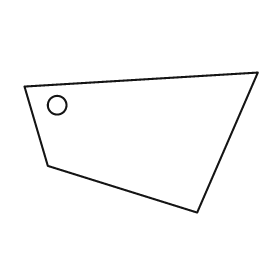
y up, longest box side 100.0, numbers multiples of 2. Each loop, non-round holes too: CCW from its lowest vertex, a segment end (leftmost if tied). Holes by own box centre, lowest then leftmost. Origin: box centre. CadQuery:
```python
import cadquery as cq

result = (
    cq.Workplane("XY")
    .moveTo(24.0, -30.0)
    .lineTo(50.0, 30.0)
    .lineTo(-50.0, 24.0)
    .lineTo(-40.0, -10.0)
    .close()
    .moveTo(-36.0, 16.0)
    .circle(4.0)
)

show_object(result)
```